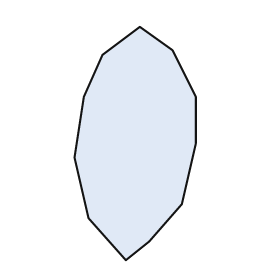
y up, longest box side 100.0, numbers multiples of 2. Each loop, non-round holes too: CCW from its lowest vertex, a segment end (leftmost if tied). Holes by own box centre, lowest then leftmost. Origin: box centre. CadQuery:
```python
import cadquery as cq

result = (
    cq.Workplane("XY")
    .moveTo(-4.0, -50.0)
    .lineTo(6.0, -42.0)
    .lineTo(20.0, -26.0)
    .lineTo(26.0, 0.0)
    .lineTo(26.0, 20.0)
    .lineTo(16.0, 40.0)
    .lineTo(2.0, 50.0)
    .lineTo(-14.0, 38.0)
    .lineTo(-22.0, 20.0)
    .lineTo(-26.0, -6.0)
    .lineTo(-20.0, -32.0)
    .close()
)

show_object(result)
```